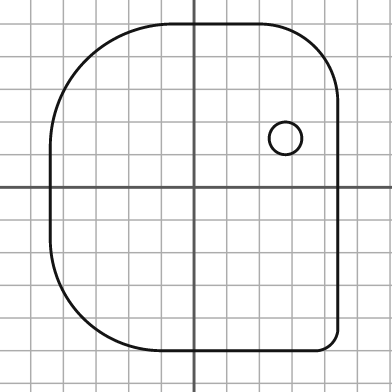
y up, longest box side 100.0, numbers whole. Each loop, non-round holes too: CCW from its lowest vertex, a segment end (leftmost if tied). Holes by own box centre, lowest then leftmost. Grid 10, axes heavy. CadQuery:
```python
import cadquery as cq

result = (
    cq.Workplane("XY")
    .moveTo(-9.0, -50.0)
    .lineTo(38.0, -50.0)
    .threePointArc((42.0, -48.0), (44.0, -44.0))
    .lineTo(44.0, 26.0)
    .threePointArc((37.0, 43.0), (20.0, 50.0))
    .lineTo(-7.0, 50.0)
    .threePointArc((-33.0, 39.0), (-44.0, 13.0))
    .lineTo(-44.0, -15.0)
    .threePointArc((-34.0, -40.0), (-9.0, -50.0))
    .close()
    .moveTo(28.0, 15.0)
    .circle(5.0)
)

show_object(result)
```